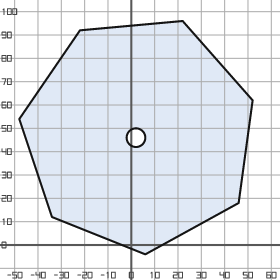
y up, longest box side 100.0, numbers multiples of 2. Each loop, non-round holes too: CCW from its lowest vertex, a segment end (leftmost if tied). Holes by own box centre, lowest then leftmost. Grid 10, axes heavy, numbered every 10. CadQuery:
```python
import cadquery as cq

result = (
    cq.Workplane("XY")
    .moveTo(6.0, -4.0)
    .lineTo(46.0, 18.0)
    .lineTo(52.0, 62.0)
    .lineTo(22.0, 96.0)
    .lineTo(-22.0, 92.0)
    .lineTo(-48.0, 54.0)
    .lineTo(-34.0, 12.0)
    .close()
    .moveTo(2.0, 46.0)
    .circle(4.0)
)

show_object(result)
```